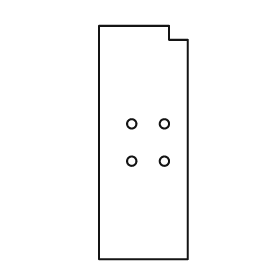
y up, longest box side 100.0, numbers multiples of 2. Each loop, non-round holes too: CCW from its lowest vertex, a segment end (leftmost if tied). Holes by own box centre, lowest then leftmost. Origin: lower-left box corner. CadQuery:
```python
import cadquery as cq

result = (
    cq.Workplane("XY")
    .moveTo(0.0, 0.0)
    .lineTo(38.0, 0.0)
    .lineTo(38.0, 94.0)
    .lineTo(30.0, 94.0)
    .lineTo(30.0, 100.0)
    .lineTo(0.0, 100.0)
    .close()
    .moveTo(14.0, 42.0)
    .circle(2.0)
    .moveTo(28.0, 42.0)
    .circle(2.0)
    .moveTo(14.0, 58.0)
    .circle(2.0)
    .moveTo(28.0, 58.0)
    .circle(2.0)
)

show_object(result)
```